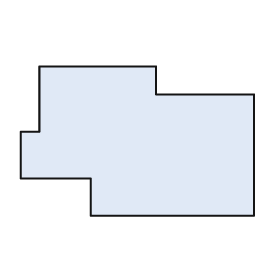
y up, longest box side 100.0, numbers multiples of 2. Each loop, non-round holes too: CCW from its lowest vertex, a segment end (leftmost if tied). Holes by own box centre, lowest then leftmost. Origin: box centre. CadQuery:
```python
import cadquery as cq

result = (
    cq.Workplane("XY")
    .moveTo(-20.0, -32.0)
    .lineTo(50.0, -32.0)
    .lineTo(50.0, 20.0)
    .lineTo(8.0, 20.0)
    .lineTo(8.0, 32.0)
    .lineTo(-42.0, 32.0)
    .lineTo(-42.0, 4.0)
    .lineTo(-50.0, 4.0)
    .lineTo(-50.0, -16.0)
    .lineTo(-20.0, -16.0)
    .close()
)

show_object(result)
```